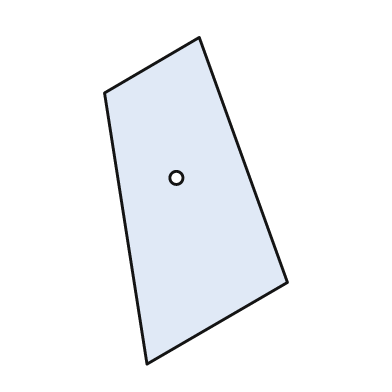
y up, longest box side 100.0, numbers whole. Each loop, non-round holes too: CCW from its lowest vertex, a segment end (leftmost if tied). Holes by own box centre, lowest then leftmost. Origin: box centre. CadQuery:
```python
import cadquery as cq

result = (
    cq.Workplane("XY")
    .moveTo(-15.0, -50.0)
    .lineTo(28.0, -25.0)
    .lineTo(1.0, 50.0)
    .lineTo(-28.0, 33.0)
    .close()
    .moveTo(-6.0, 7.0)
    .circle(2.0)
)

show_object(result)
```